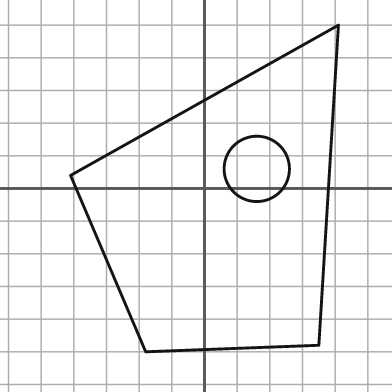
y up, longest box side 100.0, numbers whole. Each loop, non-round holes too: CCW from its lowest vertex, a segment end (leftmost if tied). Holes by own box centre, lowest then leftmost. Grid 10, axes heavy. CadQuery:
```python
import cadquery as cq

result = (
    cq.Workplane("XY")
    .moveTo(-18.0, -50.0)
    .lineTo(35.0, -48.0)
    .lineTo(41.0, 50.0)
    .lineTo(-41.0, 4.0)
    .close()
    .moveTo(16.0, 6.0)
    .circle(10.0)
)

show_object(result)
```